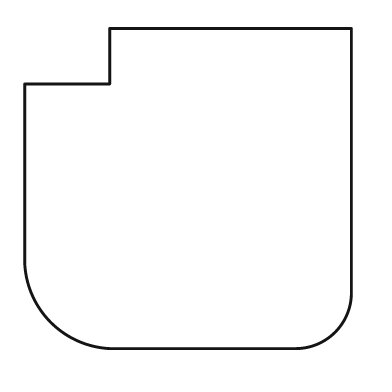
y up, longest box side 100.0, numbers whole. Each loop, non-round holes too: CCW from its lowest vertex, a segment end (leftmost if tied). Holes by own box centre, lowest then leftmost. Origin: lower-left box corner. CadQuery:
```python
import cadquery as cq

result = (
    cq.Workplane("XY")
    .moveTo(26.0, 0.0)
    .lineTo(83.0, 0.0)
    .threePointArc((95.0, 5.0), (100.0, 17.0))
    .lineTo(100.0, 98.0)
    .lineTo(26.0, 98.0)
    .lineTo(26.0, 81.0)
    .lineTo(0.0, 81.0)
    .lineTo(0.0, 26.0)
    .threePointArc((8.0, 8.0), (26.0, 0.0))
    .close()
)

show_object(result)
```